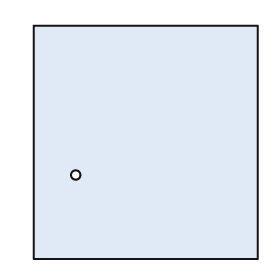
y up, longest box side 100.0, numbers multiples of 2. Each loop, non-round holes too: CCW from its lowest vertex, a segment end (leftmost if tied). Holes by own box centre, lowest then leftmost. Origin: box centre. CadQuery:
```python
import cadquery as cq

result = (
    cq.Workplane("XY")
    .moveTo(-48.0, -50.0)
    .lineTo(48.0, -50.0)
    .lineTo(48.0, 50.0)
    .lineTo(-48.0, 50.0)
    .close()
    .moveTo(-30.0, -14.0)
    .circle(2.0)
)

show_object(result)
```